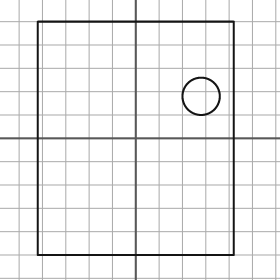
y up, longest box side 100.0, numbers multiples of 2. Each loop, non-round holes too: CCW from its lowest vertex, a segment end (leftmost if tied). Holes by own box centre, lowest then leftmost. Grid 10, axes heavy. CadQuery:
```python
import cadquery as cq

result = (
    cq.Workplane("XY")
    .moveTo(-42.0, -50.0)
    .lineTo(42.0, -50.0)
    .lineTo(42.0, 50.0)
    .lineTo(-42.0, 50.0)
    .close()
    .moveTo(28.0, 18.0)
    .circle(8.0)
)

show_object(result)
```